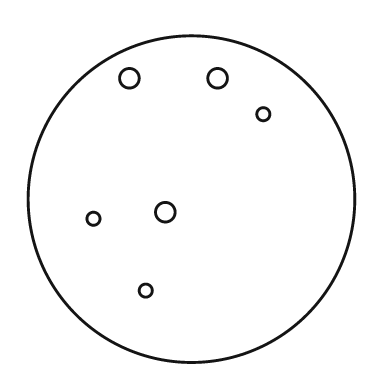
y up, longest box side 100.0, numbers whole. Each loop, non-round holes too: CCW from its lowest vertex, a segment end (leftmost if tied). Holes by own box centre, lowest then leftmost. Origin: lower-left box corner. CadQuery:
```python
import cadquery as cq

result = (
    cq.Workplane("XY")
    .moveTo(50.0, 50.0)
    .circle(50.0)
    .moveTo(36.0, 22.0)
    .circle(2.0)
    .moveTo(20.0, 44.0)
    .circle(2.0)
    .moveTo(42.0, 46.0)
    .circle(3.0)
    .moveTo(72.0, 76.0)
    .circle(2.0)
    .moveTo(31.0, 87.0)
    .circle(3.0)
    .moveTo(58.0, 87.0)
    .circle(3.0)
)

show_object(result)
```